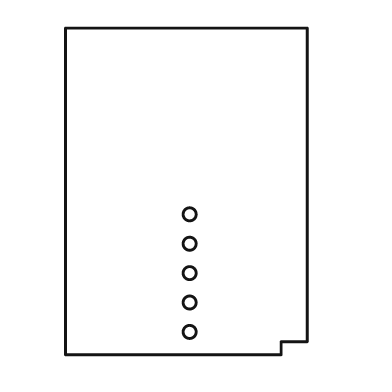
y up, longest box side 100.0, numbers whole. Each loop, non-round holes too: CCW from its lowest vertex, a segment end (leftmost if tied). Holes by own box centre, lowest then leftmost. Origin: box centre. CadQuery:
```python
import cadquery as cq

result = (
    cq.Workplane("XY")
    .moveTo(-37.0, -50.0)
    .lineTo(29.0, -50.0)
    .lineTo(29.0, -46.0)
    .lineTo(37.0, -46.0)
    .lineTo(37.0, 50.0)
    .lineTo(-37.0, 50.0)
    .close()
    .moveTo(1.0, -43.0)
    .circle(2.0)
    .moveTo(1.0, -34.0)
    .circle(2.0)
    .moveTo(1.0, -25.0)
    .circle(2.0)
    .moveTo(1.0, -16.0)
    .circle(2.0)
    .moveTo(1.0, -7.0)
    .circle(2.0)
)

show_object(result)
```